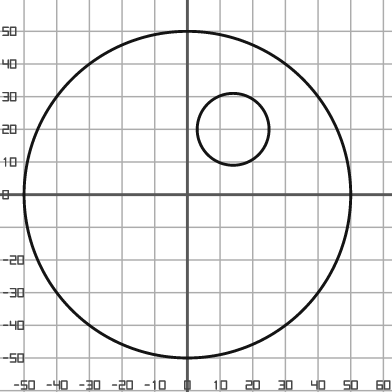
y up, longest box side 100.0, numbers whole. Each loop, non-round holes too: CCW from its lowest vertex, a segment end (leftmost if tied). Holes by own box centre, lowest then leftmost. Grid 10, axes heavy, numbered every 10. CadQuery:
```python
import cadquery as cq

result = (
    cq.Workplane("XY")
    .moveTo(0.0, 0.0)
    .circle(50.0)
    .moveTo(14.0, 20.0)
    .circle(11.0)
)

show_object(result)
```